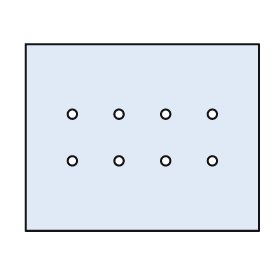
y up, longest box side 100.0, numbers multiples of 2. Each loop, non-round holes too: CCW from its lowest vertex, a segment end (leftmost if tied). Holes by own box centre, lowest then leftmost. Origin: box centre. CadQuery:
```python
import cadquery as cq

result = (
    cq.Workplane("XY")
    .moveTo(-50.0, -40.0)
    .lineTo(50.0, -40.0)
    .lineTo(50.0, 40.0)
    .lineTo(-50.0, 40.0)
    .close()
    .moveTo(-30.0, -10.0)
    .circle(2.0)
    .moveTo(-10.0, -10.0)
    .circle(2.0)
    .moveTo(10.0, -10.0)
    .circle(2.0)
    .moveTo(30.0, -10.0)
    .circle(2.0)
    .moveTo(-30.0, 10.0)
    .circle(2.0)
    .moveTo(-10.0, 10.0)
    .circle(2.0)
    .moveTo(10.0, 10.0)
    .circle(2.0)
    .moveTo(30.0, 10.0)
    .circle(2.0)
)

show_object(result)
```